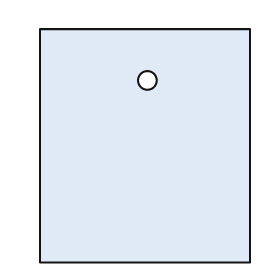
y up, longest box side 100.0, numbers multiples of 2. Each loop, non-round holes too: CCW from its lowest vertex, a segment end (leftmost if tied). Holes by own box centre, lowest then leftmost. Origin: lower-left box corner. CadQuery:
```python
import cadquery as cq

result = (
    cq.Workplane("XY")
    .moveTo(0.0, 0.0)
    .lineTo(90.0, 0.0)
    .lineTo(90.0, 100.0)
    .lineTo(0.0, 100.0)
    .close()
    .moveTo(46.0, 78.0)
    .circle(4.0)
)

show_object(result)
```